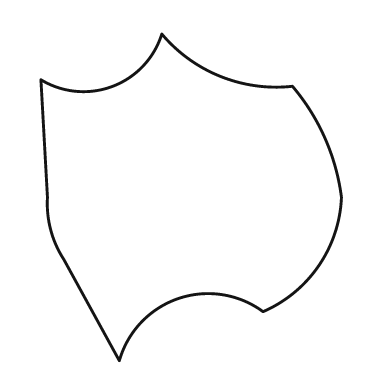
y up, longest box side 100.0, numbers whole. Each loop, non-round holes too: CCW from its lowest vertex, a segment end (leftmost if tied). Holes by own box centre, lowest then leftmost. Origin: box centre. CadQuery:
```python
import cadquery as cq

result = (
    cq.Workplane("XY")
    .moveTo(-22.0, -50.0)
    .threePointArc((-4.0, -31.0), (22.0, -35.0))
    .threePointArc((39.0, -21.0), (46.0, 0.0))
    .threePointArc((41.0, 18.0), (31.0, 34.0))
    .threePointArc((9.0, 37.0), (-9.0, 50.0))
    .threePointArc((-24.0, 34.0), (-46.0, 36.0))
    .lineTo(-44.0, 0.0)
    .threePointArc((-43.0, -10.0), (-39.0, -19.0))
    .close()
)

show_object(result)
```